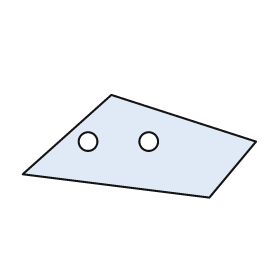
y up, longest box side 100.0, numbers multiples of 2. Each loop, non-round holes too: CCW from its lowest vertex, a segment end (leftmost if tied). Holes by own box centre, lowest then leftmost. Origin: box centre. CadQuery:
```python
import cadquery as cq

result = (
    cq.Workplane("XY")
    .moveTo(30.0, -22.0)
    .lineTo(50.0, 2.0)
    .lineTo(-12.0, 22.0)
    .lineTo(-50.0, -12.0)
    .close()
    .moveTo(-22.0, 2.0)
    .circle(4.0)
    .moveTo(4.0, 2.0)
    .circle(4.0)
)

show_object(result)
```